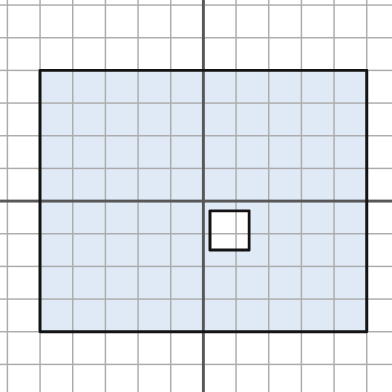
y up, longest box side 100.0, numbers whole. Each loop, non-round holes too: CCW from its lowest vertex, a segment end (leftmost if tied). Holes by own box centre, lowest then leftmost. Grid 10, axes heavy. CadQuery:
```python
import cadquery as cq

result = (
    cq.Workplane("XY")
    .moveTo(-50.0, -40.0)
    .lineTo(50.0, -40.0)
    .lineTo(50.0, 40.0)
    .lineTo(-50.0, 40.0)
    .close()
    .moveTo(2.0, -15.0)
    .lineTo(14.0, -15.0)
    .lineTo(14.0, -3.0)
    .lineTo(2.0, -3.0)
    .close()
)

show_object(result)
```